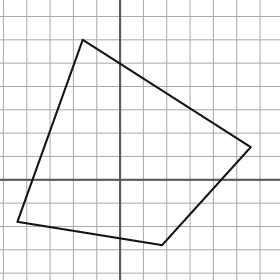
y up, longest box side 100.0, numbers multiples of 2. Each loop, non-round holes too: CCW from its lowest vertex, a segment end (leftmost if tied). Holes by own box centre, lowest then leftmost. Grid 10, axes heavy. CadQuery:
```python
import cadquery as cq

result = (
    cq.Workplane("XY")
    .moveTo(18.0, -28.0)
    .lineTo(56.0, 14.0)
    .lineTo(-16.0, 60.0)
    .lineTo(-44.0, -18.0)
    .close()
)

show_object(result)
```